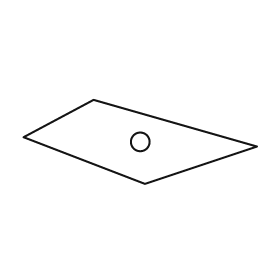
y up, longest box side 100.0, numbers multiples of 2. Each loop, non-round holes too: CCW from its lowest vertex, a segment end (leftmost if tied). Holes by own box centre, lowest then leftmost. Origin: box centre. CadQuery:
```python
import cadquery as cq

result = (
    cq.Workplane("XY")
    .moveTo(2.0, -18.0)
    .lineTo(50.0, -2.0)
    .lineTo(-20.0, 18.0)
    .lineTo(-50.0, 2.0)
    .close()
    .moveTo(0.0, 0.0)
    .circle(4.0)
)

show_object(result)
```